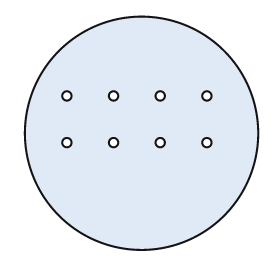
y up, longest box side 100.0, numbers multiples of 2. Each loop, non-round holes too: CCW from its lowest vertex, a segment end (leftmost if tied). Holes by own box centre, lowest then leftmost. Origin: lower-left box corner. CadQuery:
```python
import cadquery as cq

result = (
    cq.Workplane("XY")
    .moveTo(50.0, 50.0)
    .circle(50.0)
    .moveTo(18.0, 46.0)
    .circle(2.0)
    .moveTo(38.0, 46.0)
    .circle(2.0)
    .moveTo(58.0, 46.0)
    .circle(2.0)
    .moveTo(78.0, 46.0)
    .circle(2.0)
    .moveTo(18.0, 66.0)
    .circle(2.0)
    .moveTo(38.0, 66.0)
    .circle(2.0)
    .moveTo(58.0, 66.0)
    .circle(2.0)
    .moveTo(78.0, 66.0)
    .circle(2.0)
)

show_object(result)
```